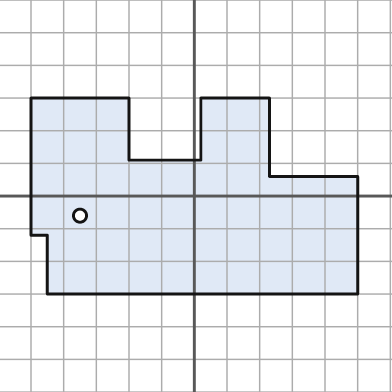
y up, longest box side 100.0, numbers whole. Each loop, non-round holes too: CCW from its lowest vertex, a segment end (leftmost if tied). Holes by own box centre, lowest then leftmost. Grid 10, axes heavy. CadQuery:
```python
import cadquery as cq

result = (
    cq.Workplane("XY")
    .moveTo(-45.0, -30.0)
    .lineTo(50.0, -30.0)
    .lineTo(50.0, 6.0)
    .lineTo(23.0, 6.0)
    .lineTo(23.0, 30.0)
    .lineTo(2.0, 30.0)
    .lineTo(2.0, 11.0)
    .lineTo(-20.0, 11.0)
    .lineTo(-20.0, 30.0)
    .lineTo(-50.0, 30.0)
    .lineTo(-50.0, -12.0)
    .lineTo(-45.0, -12.0)
    .close()
    .moveTo(-35.0, -6.0)
    .circle(2.0)
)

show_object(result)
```